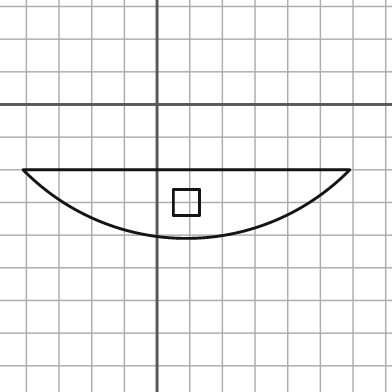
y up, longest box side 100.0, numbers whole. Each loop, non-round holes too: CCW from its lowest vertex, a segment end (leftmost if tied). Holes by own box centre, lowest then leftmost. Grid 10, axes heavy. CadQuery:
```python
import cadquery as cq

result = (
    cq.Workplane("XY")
    .moveTo(-41.0, -20.0)
    .threePointArc((9.0, -41.0), (59.0, -20.0))
    .close()
    .moveTo(5.0, -34.0)
    .lineTo(13.0, -34.0)
    .lineTo(13.0, -26.0)
    .lineTo(5.0, -26.0)
    .close()
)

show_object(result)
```